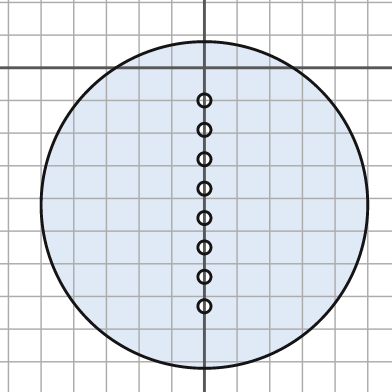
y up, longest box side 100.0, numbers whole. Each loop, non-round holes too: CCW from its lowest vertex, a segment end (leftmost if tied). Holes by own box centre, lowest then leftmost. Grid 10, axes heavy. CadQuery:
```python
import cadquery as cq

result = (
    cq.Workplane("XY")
    .moveTo(0.0, -42.0)
    .circle(50.0)
    .moveTo(0.0, -73.0)
    .circle(2.0)
    .moveTo(0.0, -64.0)
    .circle(2.0)
    .moveTo(0.0, -55.0)
    .circle(2.0)
    .moveTo(0.0, -46.0)
    .circle(2.0)
    .moveTo(0.0, -37.0)
    .circle(2.0)
    .moveTo(0.0, -28.0)
    .circle(2.0)
    .moveTo(0.0, -19.0)
    .circle(2.0)
    .moveTo(0.0, -10.0)
    .circle(2.0)
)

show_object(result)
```